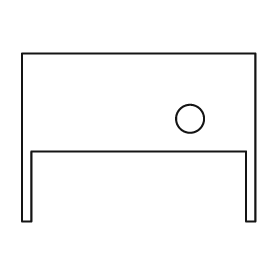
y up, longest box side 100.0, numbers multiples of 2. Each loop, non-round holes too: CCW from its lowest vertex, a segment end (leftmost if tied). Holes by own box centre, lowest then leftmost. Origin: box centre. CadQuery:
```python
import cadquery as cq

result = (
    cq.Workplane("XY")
    .moveTo(-50.0, -36.0)
    .lineTo(-46.0, -36.0)
    .lineTo(-46.0, -6.0)
    .lineTo(46.0, -6.0)
    .lineTo(46.0, -36.0)
    .lineTo(50.0, -36.0)
    .lineTo(50.0, 36.0)
    .lineTo(-50.0, 36.0)
    .close()
    .moveTo(22.0, 8.0)
    .circle(6.0)
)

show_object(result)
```